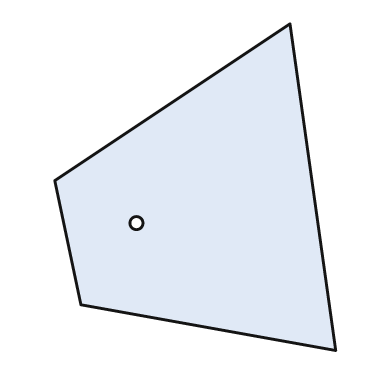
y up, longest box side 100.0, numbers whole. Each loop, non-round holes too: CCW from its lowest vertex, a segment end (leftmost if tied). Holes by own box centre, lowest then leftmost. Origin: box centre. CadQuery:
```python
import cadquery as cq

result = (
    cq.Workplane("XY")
    .moveTo(43.0, -50.0)
    .lineTo(29.0, 50.0)
    .lineTo(-43.0, 2.0)
    .lineTo(-35.0, -36.0)
    .close()
    .moveTo(-18.0, -11.0)
    .circle(2.0)
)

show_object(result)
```